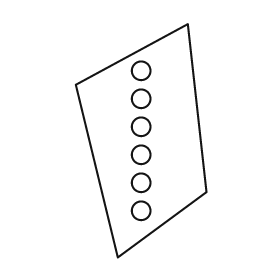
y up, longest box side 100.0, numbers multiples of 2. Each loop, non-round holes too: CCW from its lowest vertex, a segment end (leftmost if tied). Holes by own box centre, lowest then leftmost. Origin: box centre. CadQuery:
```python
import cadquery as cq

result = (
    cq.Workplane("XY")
    .moveTo(-10.0, -50.0)
    .lineTo(28.0, -22.0)
    .lineTo(20.0, 50.0)
    .lineTo(-28.0, 24.0)
    .close()
    .moveTo(0.0, -30.0)
    .circle(4.0)
    .moveTo(0.0, -18.0)
    .circle(4.0)
    .moveTo(0.0, -6.0)
    .circle(4.0)
    .moveTo(0.0, 6.0)
    .circle(4.0)
    .moveTo(0.0, 18.0)
    .circle(4.0)
    .moveTo(0.0, 30.0)
    .circle(4.0)
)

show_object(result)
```